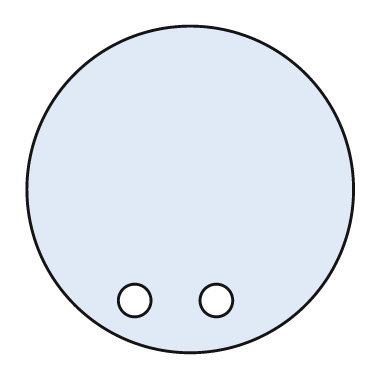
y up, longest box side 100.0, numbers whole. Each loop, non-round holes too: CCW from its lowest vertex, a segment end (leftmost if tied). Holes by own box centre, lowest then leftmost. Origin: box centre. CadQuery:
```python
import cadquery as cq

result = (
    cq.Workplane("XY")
    .moveTo(0.0, 0.0)
    .circle(50.0)
    .moveTo(-17.0, -34.0)
    .circle(5.0)
    .moveTo(8.0, -34.0)
    .circle(5.0)
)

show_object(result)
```